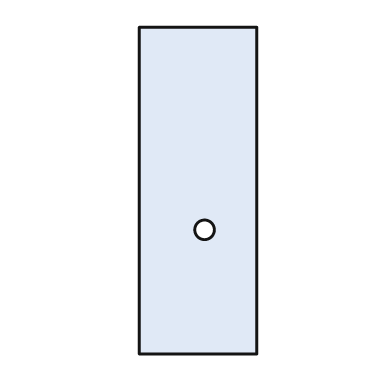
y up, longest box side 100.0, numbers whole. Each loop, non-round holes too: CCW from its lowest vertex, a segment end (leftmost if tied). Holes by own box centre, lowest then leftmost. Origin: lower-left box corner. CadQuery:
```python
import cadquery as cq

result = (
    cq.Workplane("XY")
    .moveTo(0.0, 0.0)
    .lineTo(36.0, 0.0)
    .lineTo(36.0, 100.0)
    .lineTo(0.0, 100.0)
    .close()
    .moveTo(20.0, 38.0)
    .circle(3.0)
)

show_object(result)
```